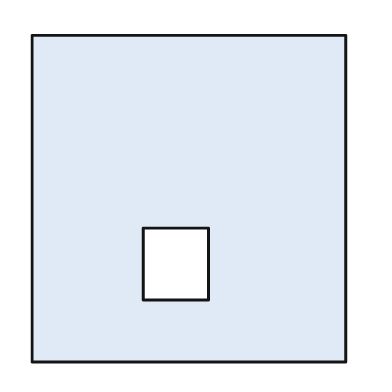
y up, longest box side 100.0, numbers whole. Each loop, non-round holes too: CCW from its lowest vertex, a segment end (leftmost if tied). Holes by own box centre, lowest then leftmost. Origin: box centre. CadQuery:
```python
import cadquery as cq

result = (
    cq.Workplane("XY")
    .moveTo(-48.0, -50.0)
    .lineTo(48.0, -50.0)
    .lineTo(48.0, 50.0)
    .lineTo(-48.0, 50.0)
    .close()
    .moveTo(-14.0, -31.0)
    .lineTo(6.0, -31.0)
    .lineTo(6.0, -9.0)
    .lineTo(-14.0, -9.0)
    .close()
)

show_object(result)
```